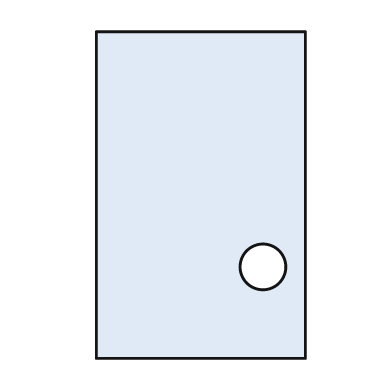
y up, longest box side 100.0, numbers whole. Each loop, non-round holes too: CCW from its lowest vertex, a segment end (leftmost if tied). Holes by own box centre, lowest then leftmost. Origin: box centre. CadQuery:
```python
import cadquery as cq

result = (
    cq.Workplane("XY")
    .moveTo(-32.0, -50.0)
    .lineTo(32.0, -50.0)
    .lineTo(32.0, 50.0)
    .lineTo(-32.0, 50.0)
    .close()
    .moveTo(19.0, -22.0)
    .circle(7.0)
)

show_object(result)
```